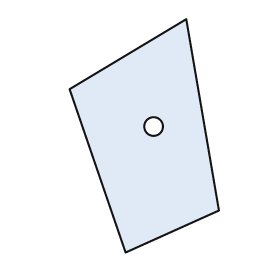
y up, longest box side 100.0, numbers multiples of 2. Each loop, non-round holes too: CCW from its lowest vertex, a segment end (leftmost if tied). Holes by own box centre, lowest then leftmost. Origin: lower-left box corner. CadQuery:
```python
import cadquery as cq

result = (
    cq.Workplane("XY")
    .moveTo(24.0, 0.0)
    .lineTo(64.0, 18.0)
    .lineTo(50.0, 100.0)
    .lineTo(0.0, 70.0)
    .close()
    .moveTo(36.0, 54.0)
    .circle(4.0)
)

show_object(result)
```